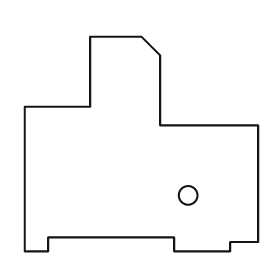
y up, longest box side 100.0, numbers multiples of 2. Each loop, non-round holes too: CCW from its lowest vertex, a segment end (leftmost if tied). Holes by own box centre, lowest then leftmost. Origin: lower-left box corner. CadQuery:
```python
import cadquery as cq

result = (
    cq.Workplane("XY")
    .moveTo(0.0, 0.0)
    .lineTo(10.0, 0.0)
    .lineTo(10.0, 6.0)
    .lineTo(64.0, 6.0)
    .lineTo(64.0, 0.0)
    .lineTo(88.0, 0.0)
    .lineTo(88.0, 4.0)
    .lineTo(100.0, 4.0)
    .lineTo(100.0, 54.0)
    .lineTo(58.0, 54.0)
    .lineTo(58.0, 84.0)
    .lineTo(50.0, 92.0)
    .lineTo(28.0, 92.0)
    .lineTo(28.0, 62.0)
    .lineTo(0.0, 62.0)
    .close()
    .moveTo(70.0, 24.0)
    .circle(4.0)
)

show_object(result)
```